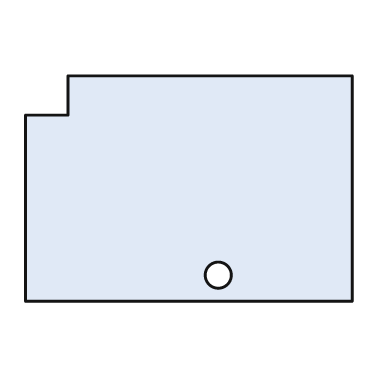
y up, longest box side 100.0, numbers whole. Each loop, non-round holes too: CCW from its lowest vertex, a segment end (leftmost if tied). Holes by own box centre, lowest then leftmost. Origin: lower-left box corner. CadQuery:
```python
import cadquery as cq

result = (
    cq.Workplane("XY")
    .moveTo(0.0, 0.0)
    .lineTo(100.0, 0.0)
    .lineTo(100.0, 69.0)
    .lineTo(13.0, 69.0)
    .lineTo(13.0, 57.0)
    .lineTo(0.0, 57.0)
    .close()
    .moveTo(59.0, 8.0)
    .circle(4.0)
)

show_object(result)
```